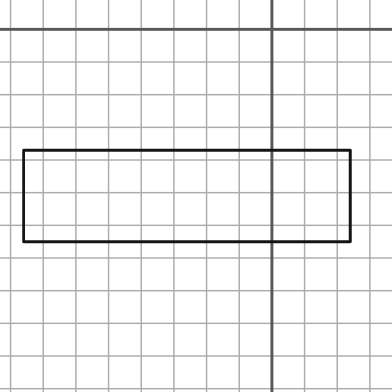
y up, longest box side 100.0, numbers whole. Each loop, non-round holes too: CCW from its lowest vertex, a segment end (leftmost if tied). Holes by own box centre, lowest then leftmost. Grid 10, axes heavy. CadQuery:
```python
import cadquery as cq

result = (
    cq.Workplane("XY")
    .moveTo(-76.0, -65.0)
    .lineTo(24.0, -65.0)
    .lineTo(24.0, -37.0)
    .lineTo(-76.0, -37.0)
    .close()
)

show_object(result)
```